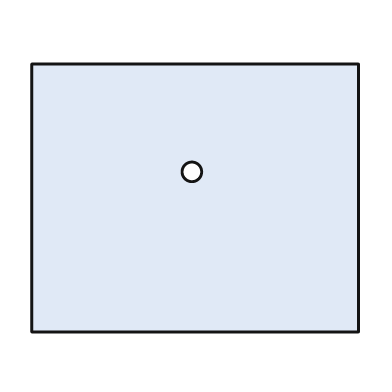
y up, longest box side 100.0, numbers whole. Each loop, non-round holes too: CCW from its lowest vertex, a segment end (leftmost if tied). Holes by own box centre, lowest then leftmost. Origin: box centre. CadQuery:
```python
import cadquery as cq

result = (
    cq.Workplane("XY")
    .moveTo(-50.0, -41.0)
    .lineTo(50.0, -41.0)
    .lineTo(50.0, 41.0)
    .lineTo(-50.0, 41.0)
    .close()
    .moveTo(-1.0, 8.0)
    .circle(3.0)
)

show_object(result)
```